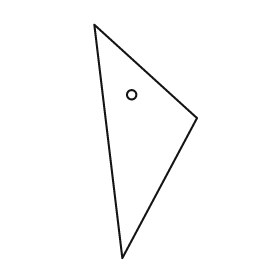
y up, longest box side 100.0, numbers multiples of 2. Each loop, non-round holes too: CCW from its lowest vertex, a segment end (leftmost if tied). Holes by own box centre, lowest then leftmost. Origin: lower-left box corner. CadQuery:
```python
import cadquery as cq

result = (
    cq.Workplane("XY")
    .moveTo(12.0, 0.0)
    .lineTo(44.0, 60.0)
    .lineTo(0.0, 100.0)
    .close()
    .moveTo(16.0, 70.0)
    .circle(2.0)
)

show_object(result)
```